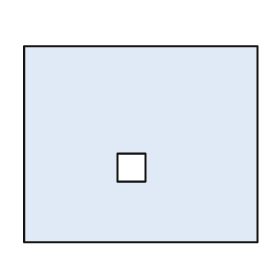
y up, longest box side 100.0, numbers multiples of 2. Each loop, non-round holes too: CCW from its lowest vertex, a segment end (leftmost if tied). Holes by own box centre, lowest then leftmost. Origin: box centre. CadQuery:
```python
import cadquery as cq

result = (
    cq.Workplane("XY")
    .moveTo(-50.0, -42.0)
    .lineTo(50.0, -42.0)
    .lineTo(50.0, 42.0)
    .lineTo(-50.0, 42.0)
    .close()
    .moveTo(-10.0, -16.0)
    .lineTo(2.0, -16.0)
    .lineTo(2.0, -4.0)
    .lineTo(-10.0, -4.0)
    .close()
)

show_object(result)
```